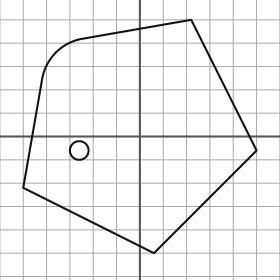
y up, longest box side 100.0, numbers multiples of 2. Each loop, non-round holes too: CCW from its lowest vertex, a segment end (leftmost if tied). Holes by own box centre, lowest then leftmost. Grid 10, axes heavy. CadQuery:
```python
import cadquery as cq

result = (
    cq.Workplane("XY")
    .moveTo(6.0, -50.0)
    .lineTo(50.0, -6.0)
    .lineTo(22.0, 50.0)
    .lineTo(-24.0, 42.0)
    .threePointArc((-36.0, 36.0), (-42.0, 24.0))
    .lineTo(-50.0, -22.0)
    .close()
    .moveTo(-26.0, -6.0)
    .circle(4.0)
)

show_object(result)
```